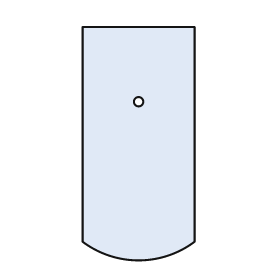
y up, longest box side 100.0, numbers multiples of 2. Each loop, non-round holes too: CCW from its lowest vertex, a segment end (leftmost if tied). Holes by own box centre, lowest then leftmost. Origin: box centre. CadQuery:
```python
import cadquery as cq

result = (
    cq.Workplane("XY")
    .moveTo(-24.0, -42.0)
    .threePointArc((0.0, -50.0), (24.0, -42.0))
    .lineTo(24.0, 50.0)
    .lineTo(-24.0, 50.0)
    .close()
    .moveTo(0.0, 18.0)
    .circle(2.0)
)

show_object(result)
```